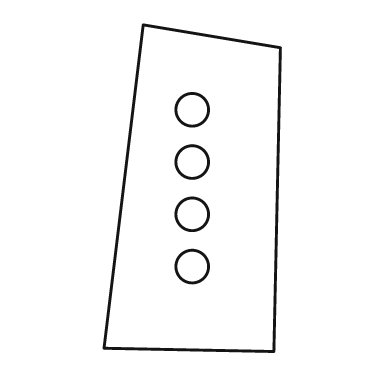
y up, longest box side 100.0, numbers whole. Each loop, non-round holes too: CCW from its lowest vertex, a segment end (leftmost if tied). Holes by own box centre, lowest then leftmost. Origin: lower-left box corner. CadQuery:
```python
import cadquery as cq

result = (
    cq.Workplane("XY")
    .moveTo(52.0, 0.0)
    .lineTo(54.0, 93.0)
    .lineTo(12.0, 100.0)
    .lineTo(0.0, 1.0)
    .close()
    .moveTo(27.0, 26.0)
    .circle(5.0)
    .moveTo(27.0, 42.0)
    .circle(5.0)
    .moveTo(27.0, 58.0)
    .circle(5.0)
    .moveTo(27.0, 74.0)
    .circle(5.0)
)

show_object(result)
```